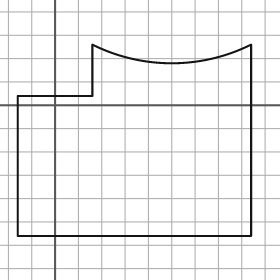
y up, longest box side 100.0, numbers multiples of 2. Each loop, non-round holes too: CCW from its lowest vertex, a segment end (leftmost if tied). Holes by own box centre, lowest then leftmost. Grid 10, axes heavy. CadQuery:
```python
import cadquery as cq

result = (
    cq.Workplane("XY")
    .moveTo(-16.0, -56.0)
    .lineTo(84.0, -56.0)
    .lineTo(84.0, 26.0)
    .threePointArc((50.0, 18.0), (16.0, 26.0))
    .lineTo(16.0, 4.0)
    .lineTo(-16.0, 4.0)
    .close()
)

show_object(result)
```